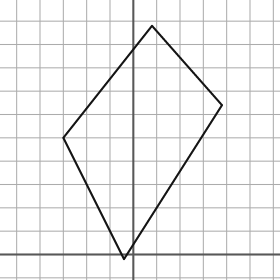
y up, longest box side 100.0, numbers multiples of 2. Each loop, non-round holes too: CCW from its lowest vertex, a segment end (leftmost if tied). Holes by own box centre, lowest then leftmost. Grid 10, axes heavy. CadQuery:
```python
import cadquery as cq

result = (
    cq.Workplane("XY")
    .moveTo(-4.0, -2.0)
    .lineTo(38.0, 64.0)
    .lineTo(8.0, 98.0)
    .lineTo(-30.0, 50.0)
    .close()
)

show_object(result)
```